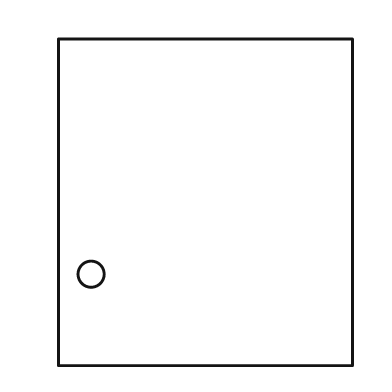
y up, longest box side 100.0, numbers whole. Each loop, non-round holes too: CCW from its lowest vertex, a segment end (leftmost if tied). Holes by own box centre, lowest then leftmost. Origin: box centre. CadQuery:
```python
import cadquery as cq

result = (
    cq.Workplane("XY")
    .moveTo(-45.0, -50.0)
    .lineTo(45.0, -50.0)
    .lineTo(45.0, 50.0)
    .lineTo(-45.0, 50.0)
    .close()
    .moveTo(-35.0, -22.0)
    .circle(4.0)
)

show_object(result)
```